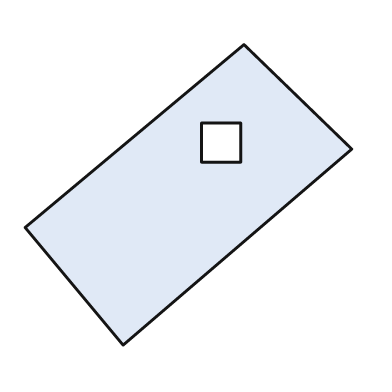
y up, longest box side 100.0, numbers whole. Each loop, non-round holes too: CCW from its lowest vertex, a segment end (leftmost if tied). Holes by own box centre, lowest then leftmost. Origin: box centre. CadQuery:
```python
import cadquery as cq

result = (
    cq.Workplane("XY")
    .moveTo(-20.0, -46.0)
    .lineTo(50.0, 14.0)
    .lineTo(17.0, 46.0)
    .lineTo(-50.0, -10.0)
    .close()
    .moveTo(4.0, 10.0)
    .lineTo(16.0, 10.0)
    .lineTo(16.0, 22.0)
    .lineTo(4.0, 22.0)
    .close()
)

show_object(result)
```